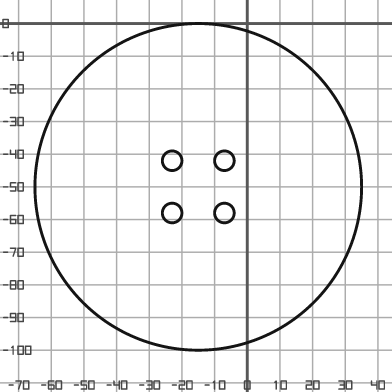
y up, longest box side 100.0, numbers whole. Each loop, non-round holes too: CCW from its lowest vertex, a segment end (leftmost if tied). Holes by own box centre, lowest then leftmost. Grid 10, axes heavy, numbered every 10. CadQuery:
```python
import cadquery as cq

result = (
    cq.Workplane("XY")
    .moveTo(-15.0, -50.0)
    .circle(50.0)
    .moveTo(-23.0, -58.0)
    .circle(3.0)
    .moveTo(-7.0, -58.0)
    .circle(3.0)
    .moveTo(-23.0, -42.0)
    .circle(3.0)
    .moveTo(-7.0, -42.0)
    .circle(3.0)
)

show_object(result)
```